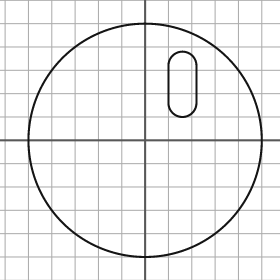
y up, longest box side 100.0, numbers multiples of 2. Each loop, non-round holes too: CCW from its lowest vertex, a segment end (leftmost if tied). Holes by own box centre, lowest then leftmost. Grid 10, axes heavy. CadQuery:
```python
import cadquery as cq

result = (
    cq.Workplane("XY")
    .moveTo(0.0, 0.0)
    .circle(50.0)
    .moveTo(10.0, 16.0)
    .threePointArc((16.0, 10.0), (22.0, 16.0))
    .lineTo(22.0, 32.0)
    .threePointArc((16.0, 38.0), (10.0, 32.0))
    .close()
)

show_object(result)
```